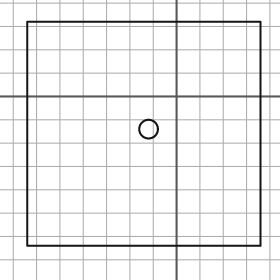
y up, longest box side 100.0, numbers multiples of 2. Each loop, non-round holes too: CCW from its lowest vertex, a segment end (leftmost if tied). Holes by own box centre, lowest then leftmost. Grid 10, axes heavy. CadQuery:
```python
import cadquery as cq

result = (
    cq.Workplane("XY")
    .moveTo(-64.0, -64.0)
    .lineTo(36.0, -64.0)
    .lineTo(36.0, 32.0)
    .lineTo(-64.0, 32.0)
    .close()
    .moveTo(-12.0, -14.0)
    .circle(4.0)
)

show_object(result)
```